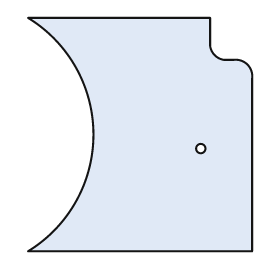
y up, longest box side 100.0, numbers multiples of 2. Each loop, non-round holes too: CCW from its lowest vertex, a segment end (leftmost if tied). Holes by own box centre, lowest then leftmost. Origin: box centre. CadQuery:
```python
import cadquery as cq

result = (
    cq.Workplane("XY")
    .moveTo(-48.0, -50.0)
    .lineTo(48.0, -50.0)
    .lineTo(48.0, 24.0)
    .threePointArc((46.0, 30.0), (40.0, 32.0))
    .lineTo(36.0, 32.0)
    .threePointArc((32.0, 34.0), (30.0, 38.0))
    .lineTo(30.0, 50.0)
    .lineTo(-48.0, 50.0)
    .threePointArc((-20.0, 0.0), (-48.0, -50.0))
    .close()
    .moveTo(26.0, -6.0)
    .circle(2.0)
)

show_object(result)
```